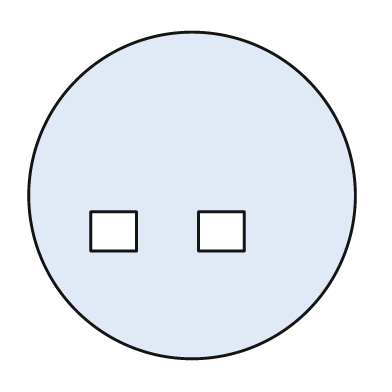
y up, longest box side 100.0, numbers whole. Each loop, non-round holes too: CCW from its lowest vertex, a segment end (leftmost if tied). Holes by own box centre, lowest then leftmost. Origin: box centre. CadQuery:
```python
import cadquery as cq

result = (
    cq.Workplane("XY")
    .moveTo(0.0, 0.0)
    .circle(50.0)
    .moveTo(-31.0, -17.0)
    .lineTo(-17.0, -17.0)
    .lineTo(-17.0, -5.0)
    .lineTo(-31.0, -5.0)
    .close()
    .moveTo(2.0, -17.0)
    .lineTo(16.0, -17.0)
    .lineTo(16.0, -5.0)
    .lineTo(2.0, -5.0)
    .close()
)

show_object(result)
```